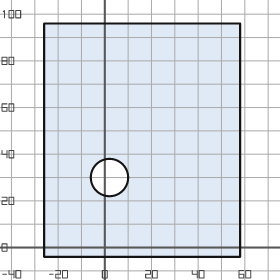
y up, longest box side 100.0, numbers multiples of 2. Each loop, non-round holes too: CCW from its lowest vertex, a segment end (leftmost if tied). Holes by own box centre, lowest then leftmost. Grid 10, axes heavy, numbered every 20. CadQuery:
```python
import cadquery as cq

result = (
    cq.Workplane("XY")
    .moveTo(-26.0, -4.0)
    .lineTo(58.0, -4.0)
    .lineTo(58.0, 96.0)
    .lineTo(-26.0, 96.0)
    .close()
    .moveTo(2.0, 30.0)
    .circle(8.0)
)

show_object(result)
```